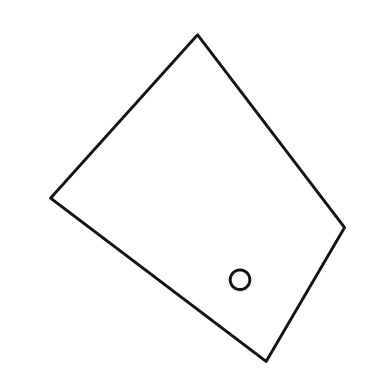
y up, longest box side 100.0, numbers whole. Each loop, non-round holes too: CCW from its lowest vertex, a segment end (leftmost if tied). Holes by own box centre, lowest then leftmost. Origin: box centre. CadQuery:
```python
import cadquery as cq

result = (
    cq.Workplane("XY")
    .moveTo(21.0, -50.0)
    .lineTo(45.0, -9.0)
    .lineTo(0.0, 50.0)
    .lineTo(-45.0, 0.0)
    .close()
    .moveTo(13.0, -25.0)
    .circle(3.0)
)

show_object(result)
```